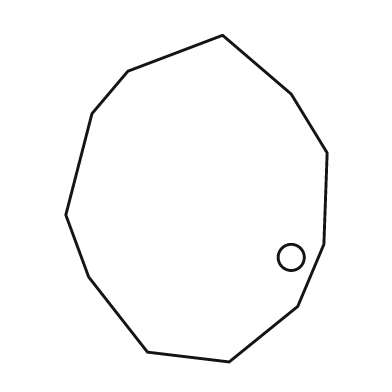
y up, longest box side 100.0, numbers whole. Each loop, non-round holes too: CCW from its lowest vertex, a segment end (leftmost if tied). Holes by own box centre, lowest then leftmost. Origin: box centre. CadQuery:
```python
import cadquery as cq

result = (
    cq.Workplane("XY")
    .moveTo(10.0, -50.0)
    .lineTo(31.0, -33.0)
    .lineTo(39.0, -14.0)
    .lineTo(40.0, 14.0)
    .lineTo(29.0, 32.0)
    .lineTo(8.0, 50.0)
    .lineTo(-21.0, 39.0)
    .lineTo(-32.0, 26.0)
    .lineTo(-40.0, -5.0)
    .lineTo(-33.0, -24.0)
    .lineTo(-15.0, -47.0)
    .close()
    .moveTo(29.0, -18.0)
    .circle(4.0)
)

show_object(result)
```